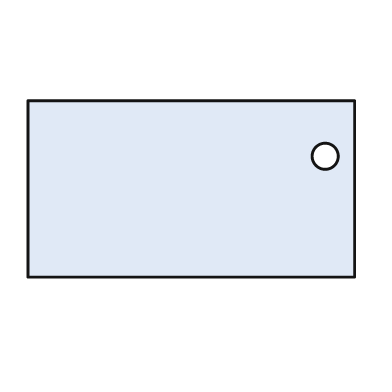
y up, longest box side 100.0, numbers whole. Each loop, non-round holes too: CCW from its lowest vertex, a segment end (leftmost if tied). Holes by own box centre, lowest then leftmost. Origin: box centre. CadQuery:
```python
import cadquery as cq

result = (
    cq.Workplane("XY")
    .moveTo(-50.0, -27.0)
    .lineTo(50.0, -27.0)
    .lineTo(50.0, 27.0)
    .lineTo(-50.0, 27.0)
    .close()
    .moveTo(41.0, 10.0)
    .circle(4.0)
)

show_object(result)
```